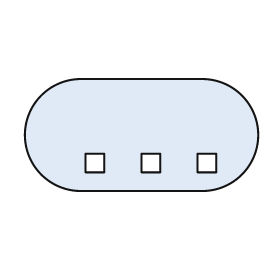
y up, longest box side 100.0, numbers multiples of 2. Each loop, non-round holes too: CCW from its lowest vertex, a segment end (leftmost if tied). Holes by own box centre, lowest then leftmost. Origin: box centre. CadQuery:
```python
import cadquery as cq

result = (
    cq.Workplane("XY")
    .moveTo(-26.0, -24.0)
    .lineTo(26.0, -24.0)
    .threePointArc((50.0, 0.0), (26.0, 24.0))
    .lineTo(-26.0, 24.0)
    .threePointArc((-50.0, 0.0), (-26.0, -24.0))
    .close()
    .moveTo(-24.0, -16.0)
    .lineTo(-16.0, -16.0)
    .lineTo(-16.0, -8.0)
    .lineTo(-24.0, -8.0)
    .close()
    .moveTo(0.0, -16.0)
    .lineTo(8.0, -16.0)
    .lineTo(8.0, -8.0)
    .lineTo(0.0, -8.0)
    .close()
    .moveTo(24.0, -16.0)
    .lineTo(32.0, -16.0)
    .lineTo(32.0, -8.0)
    .lineTo(24.0, -8.0)
    .close()
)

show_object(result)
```